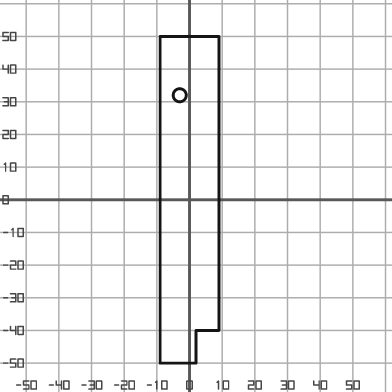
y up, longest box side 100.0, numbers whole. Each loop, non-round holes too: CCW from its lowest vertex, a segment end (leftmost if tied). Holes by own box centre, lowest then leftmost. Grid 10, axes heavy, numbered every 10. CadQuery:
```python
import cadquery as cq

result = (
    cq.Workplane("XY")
    .moveTo(-9.0, -50.0)
    .lineTo(2.0, -50.0)
    .lineTo(2.0, -40.0)
    .lineTo(9.0, -40.0)
    .lineTo(9.0, 50.0)
    .lineTo(-9.0, 50.0)
    .close()
    .moveTo(-3.0, 32.0)
    .circle(2.0)
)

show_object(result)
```